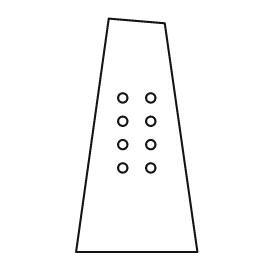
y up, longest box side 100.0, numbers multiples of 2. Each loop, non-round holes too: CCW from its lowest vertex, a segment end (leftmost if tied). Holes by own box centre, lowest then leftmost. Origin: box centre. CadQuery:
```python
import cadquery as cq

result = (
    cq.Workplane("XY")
    .moveTo(-26.0, -50.0)
    .lineTo(26.0, -50.0)
    .lineTo(12.0, 48.0)
    .lineTo(-12.0, 50.0)
    .close()
    .moveTo(-6.0, -14.0)
    .circle(2.0)
    .moveTo(6.0, -14.0)
    .circle(2.0)
    .moveTo(-6.0, -4.0)
    .circle(2.0)
    .moveTo(6.0, -4.0)
    .circle(2.0)
    .moveTo(-6.0, 6.0)
    .circle(2.0)
    .moveTo(6.0, 6.0)
    .circle(2.0)
    .moveTo(-6.0, 16.0)
    .circle(2.0)
    .moveTo(6.0, 16.0)
    .circle(2.0)
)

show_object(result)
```